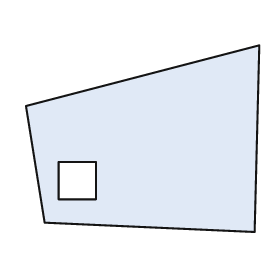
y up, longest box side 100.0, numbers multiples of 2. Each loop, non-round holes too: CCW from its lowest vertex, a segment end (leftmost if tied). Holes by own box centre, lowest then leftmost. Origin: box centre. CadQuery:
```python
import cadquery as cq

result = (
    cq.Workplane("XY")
    .moveTo(48.0, -40.0)
    .lineTo(50.0, 40.0)
    .lineTo(-50.0, 14.0)
    .lineTo(-42.0, -36.0)
    .close()
    .moveTo(-36.0, -26.0)
    .lineTo(-20.0, -26.0)
    .lineTo(-20.0, -10.0)
    .lineTo(-36.0, -10.0)
    .close()
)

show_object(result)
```